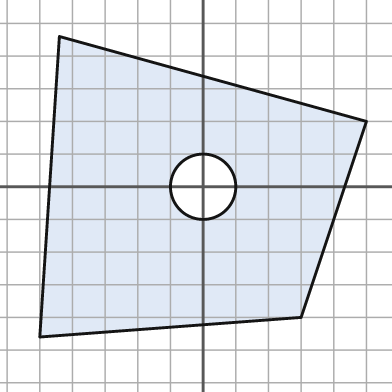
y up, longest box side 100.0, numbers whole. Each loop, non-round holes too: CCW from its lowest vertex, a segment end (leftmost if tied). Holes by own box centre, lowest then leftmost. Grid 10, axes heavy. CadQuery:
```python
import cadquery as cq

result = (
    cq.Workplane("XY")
    .moveTo(-50.0, -46.0)
    .lineTo(30.0, -40.0)
    .lineTo(50.0, 20.0)
    .lineTo(-44.0, 46.0)
    .close()
    .moveTo(0.0, 0.0)
    .circle(10.0)
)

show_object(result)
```